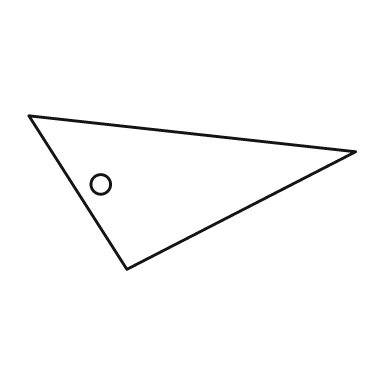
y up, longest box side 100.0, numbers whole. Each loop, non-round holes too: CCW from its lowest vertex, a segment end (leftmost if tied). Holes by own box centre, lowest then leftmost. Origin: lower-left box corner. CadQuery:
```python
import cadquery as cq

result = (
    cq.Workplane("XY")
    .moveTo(30.0, 0.0)
    .lineTo(100.0, 36.0)
    .lineTo(0.0, 47.0)
    .close()
    .moveTo(22.0, 26.0)
    .circle(3.0)
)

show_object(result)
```